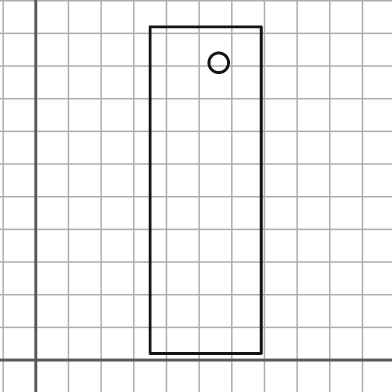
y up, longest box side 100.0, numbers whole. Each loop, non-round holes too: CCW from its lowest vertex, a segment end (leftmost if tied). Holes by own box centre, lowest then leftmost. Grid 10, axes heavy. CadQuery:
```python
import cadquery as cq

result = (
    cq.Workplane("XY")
    .moveTo(35.0, 2.0)
    .lineTo(69.0, 2.0)
    .lineTo(69.0, 102.0)
    .lineTo(35.0, 102.0)
    .close()
    .moveTo(56.0, 91.0)
    .circle(3.0)
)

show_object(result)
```